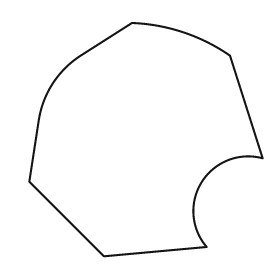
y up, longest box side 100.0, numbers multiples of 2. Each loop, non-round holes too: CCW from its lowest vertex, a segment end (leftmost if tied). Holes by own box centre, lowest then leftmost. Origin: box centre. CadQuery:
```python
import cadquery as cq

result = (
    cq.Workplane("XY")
    .moveTo(-18.0, -50.0)
    .lineTo(26.0, -46.0)
    .threePointArc((24.0, -18.0), (50.0, -8.0))
    .lineTo(36.0, 36.0)
    .threePointArc((16.0, 46.0), (-6.0, 50.0))
    .lineTo(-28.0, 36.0)
    .threePointArc((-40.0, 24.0), (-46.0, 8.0))
    .lineTo(-50.0, -18.0)
    .close()
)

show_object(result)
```